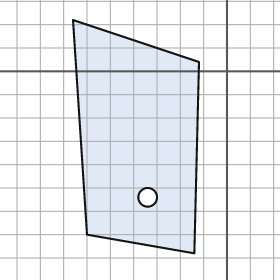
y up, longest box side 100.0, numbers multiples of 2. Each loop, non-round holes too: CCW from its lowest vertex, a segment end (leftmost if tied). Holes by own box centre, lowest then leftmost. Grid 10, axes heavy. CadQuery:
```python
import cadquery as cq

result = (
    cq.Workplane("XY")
    .moveTo(-14.0, -78.0)
    .lineTo(-12.0, 4.0)
    .lineTo(-66.0, 22.0)
    .lineTo(-60.0, -70.0)
    .close()
    .moveTo(-34.0, -54.0)
    .circle(4.0)
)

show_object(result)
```